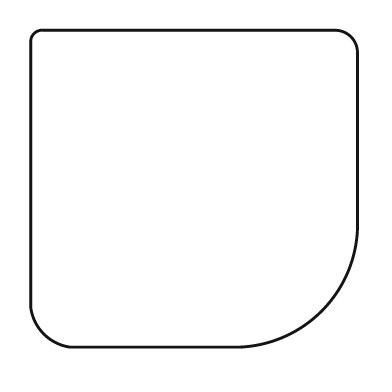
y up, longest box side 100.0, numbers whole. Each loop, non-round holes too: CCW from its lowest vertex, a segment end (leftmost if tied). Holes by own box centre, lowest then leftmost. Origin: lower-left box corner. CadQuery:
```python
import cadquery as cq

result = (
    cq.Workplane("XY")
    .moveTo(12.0, 0.0)
    .lineTo(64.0, 0.0)
    .threePointArc((89.0, 11.0), (100.0, 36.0))
    .lineTo(100.0, 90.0)
    .threePointArc((98.0, 95.0), (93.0, 97.0))
    .lineTo(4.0, 97.0)
    .threePointArc((1.0, 96.0), (0.0, 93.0))
    .lineTo(0.0, 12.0)
    .threePointArc((4.0, 4.0), (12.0, 0.0))
    .close()
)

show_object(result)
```